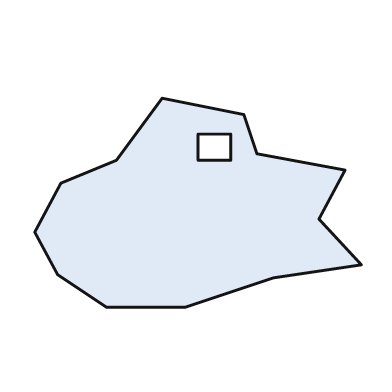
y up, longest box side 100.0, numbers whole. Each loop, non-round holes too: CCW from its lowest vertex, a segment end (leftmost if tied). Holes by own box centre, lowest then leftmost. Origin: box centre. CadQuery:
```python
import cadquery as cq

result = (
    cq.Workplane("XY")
    .moveTo(-28.0, -32.0)
    .lineTo(-4.0, -32.0)
    .lineTo(23.0, -23.0)
    .lineTo(50.0, -19.0)
    .lineTo(37.0, -5.0)
    .lineTo(45.0, 10.0)
    .lineTo(18.0, 15.0)
    .lineTo(14.0, 27.0)
    .lineTo(-11.0, 32.0)
    .lineTo(-25.0, 13.0)
    .lineTo(-42.0, 6.0)
    .lineTo(-50.0, -9.0)
    .lineTo(-43.0, -22.0)
    .close()
    .moveTo(0.0, 13.0)
    .lineTo(10.0, 13.0)
    .lineTo(10.0, 21.0)
    .lineTo(0.0, 21.0)
    .close()
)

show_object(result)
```